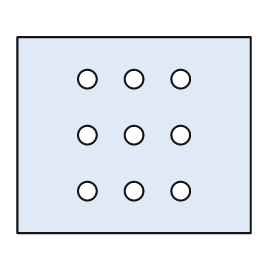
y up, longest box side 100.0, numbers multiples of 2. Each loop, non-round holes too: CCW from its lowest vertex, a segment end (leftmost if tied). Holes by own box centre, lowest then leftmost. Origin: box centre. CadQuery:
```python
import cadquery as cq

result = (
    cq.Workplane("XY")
    .moveTo(-50.0, -42.0)
    .lineTo(50.0, -42.0)
    .lineTo(50.0, 42.0)
    .lineTo(-50.0, 42.0)
    .close()
    .moveTo(-20.0, -24.0)
    .circle(4.0)
    .moveTo(0.0, -24.0)
    .circle(4.0)
    .moveTo(20.0, -24.0)
    .circle(4.0)
    .moveTo(-20.0, 0.0)
    .circle(4.0)
    .moveTo(0.0, 0.0)
    .circle(4.0)
    .moveTo(20.0, 0.0)
    .circle(4.0)
    .moveTo(-20.0, 24.0)
    .circle(4.0)
    .moveTo(0.0, 24.0)
    .circle(4.0)
    .moveTo(20.0, 24.0)
    .circle(4.0)
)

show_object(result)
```